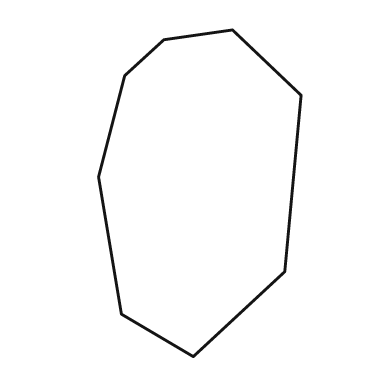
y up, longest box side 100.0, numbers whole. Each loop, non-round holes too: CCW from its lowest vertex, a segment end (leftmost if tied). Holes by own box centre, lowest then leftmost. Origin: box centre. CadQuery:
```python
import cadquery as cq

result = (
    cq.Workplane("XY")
    .moveTo(-2.0, -50.0)
    .lineTo(26.0, -24.0)
    .lineTo(31.0, 30.0)
    .lineTo(10.0, 50.0)
    .lineTo(-11.0, 47.0)
    .lineTo(-23.0, 36.0)
    .lineTo(-31.0, 5.0)
    .lineTo(-24.0, -37.0)
    .close()
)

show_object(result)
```